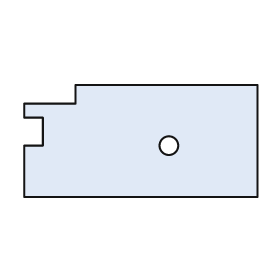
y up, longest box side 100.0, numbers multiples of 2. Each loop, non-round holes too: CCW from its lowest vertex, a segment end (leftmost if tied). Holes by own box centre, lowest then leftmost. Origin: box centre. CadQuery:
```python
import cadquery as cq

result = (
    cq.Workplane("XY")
    .moveTo(-50.0, -24.0)
    .lineTo(50.0, -24.0)
    .lineTo(50.0, 24.0)
    .lineTo(-28.0, 24.0)
    .lineTo(-28.0, 16.0)
    .lineTo(-50.0, 16.0)
    .lineTo(-50.0, 10.0)
    .lineTo(-42.0, 10.0)
    .lineTo(-42.0, -2.0)
    .lineTo(-50.0, -2.0)
    .close()
    .moveTo(12.0, -2.0)
    .circle(4.0)
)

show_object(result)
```